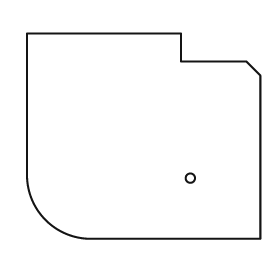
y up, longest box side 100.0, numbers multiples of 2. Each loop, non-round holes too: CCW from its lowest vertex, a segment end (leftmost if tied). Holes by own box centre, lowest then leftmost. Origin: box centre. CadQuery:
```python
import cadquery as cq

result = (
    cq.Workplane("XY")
    .moveTo(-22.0, -44.0)
    .lineTo(50.0, -44.0)
    .lineTo(50.0, 26.0)
    .lineTo(44.0, 32.0)
    .lineTo(16.0, 32.0)
    .lineTo(16.0, 44.0)
    .lineTo(-50.0, 44.0)
    .lineTo(-50.0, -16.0)
    .threePointArc((-42.0, -36.0), (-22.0, -44.0))
    .close()
    .moveTo(20.0, -18.0)
    .circle(2.0)
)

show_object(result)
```